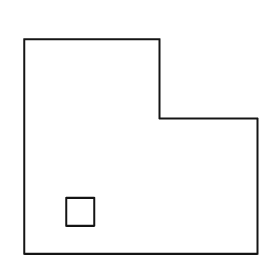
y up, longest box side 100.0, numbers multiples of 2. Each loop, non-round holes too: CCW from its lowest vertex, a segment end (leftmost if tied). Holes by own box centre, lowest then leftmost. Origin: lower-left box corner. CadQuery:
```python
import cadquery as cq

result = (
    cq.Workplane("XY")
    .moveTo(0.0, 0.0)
    .lineTo(100.0, 0.0)
    .lineTo(100.0, 58.0)
    .lineTo(58.0, 58.0)
    .lineTo(58.0, 92.0)
    .lineTo(0.0, 92.0)
    .close()
    .moveTo(18.0, 12.0)
    .lineTo(30.0, 12.0)
    .lineTo(30.0, 24.0)
    .lineTo(18.0, 24.0)
    .close()
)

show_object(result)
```